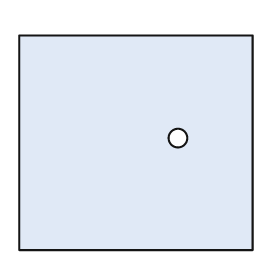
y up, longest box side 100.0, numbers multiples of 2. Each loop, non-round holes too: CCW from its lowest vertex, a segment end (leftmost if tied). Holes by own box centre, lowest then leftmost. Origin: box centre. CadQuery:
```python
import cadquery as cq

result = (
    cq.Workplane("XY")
    .moveTo(-50.0, -46.0)
    .lineTo(50.0, -46.0)
    .lineTo(50.0, 46.0)
    .lineTo(-50.0, 46.0)
    .close()
    .moveTo(18.0, 2.0)
    .circle(4.0)
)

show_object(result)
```